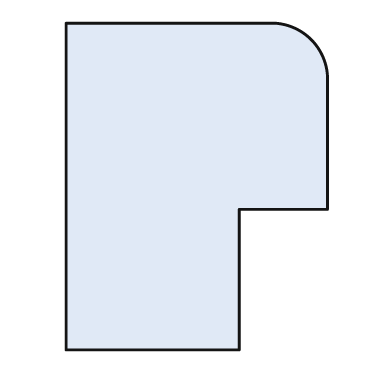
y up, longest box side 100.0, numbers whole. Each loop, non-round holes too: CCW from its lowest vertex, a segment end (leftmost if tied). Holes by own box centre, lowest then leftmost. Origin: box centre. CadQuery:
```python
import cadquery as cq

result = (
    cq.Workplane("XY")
    .moveTo(-40.0, -50.0)
    .lineTo(13.0, -50.0)
    .lineTo(13.0, -7.0)
    .lineTo(40.0, -7.0)
    .lineTo(40.0, 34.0)
    .threePointArc((35.0, 45.0), (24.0, 50.0))
    .lineTo(-40.0, 50.0)
    .close()
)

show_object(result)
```